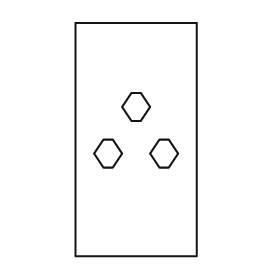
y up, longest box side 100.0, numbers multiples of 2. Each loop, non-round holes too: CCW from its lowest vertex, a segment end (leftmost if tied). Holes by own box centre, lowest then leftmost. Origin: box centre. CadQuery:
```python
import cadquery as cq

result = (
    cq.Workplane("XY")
    .moveTo(-26.0, -50.0)
    .lineTo(26.0, -50.0)
    .lineTo(26.0, 50.0)
    .lineTo(-26.0, 50.0)
    .close()
    .moveTo(-14.0, -12.0)
    .lineTo(-10.0, -12.0)
    .lineTo(-6.0, -6.0)
    .lineTo(-10.0, 0.0)
    .lineTo(-14.0, 0.0)
    .lineTo(-18.0, -6.0)
    .close()
    .moveTo(10.0, -12.0)
    .lineTo(14.0, -12.0)
    .lineTo(18.0, -6.0)
    .lineTo(14.0, 0.0)
    .lineTo(10.0, 0.0)
    .lineTo(6.0, -6.0)
    .close()
    .moveTo(-2.0, 8.0)
    .lineTo(2.0, 8.0)
    .lineTo(6.0, 14.0)
    .lineTo(2.0, 20.0)
    .lineTo(-2.0, 20.0)
    .lineTo(-6.0, 14.0)
    .close()
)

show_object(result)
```